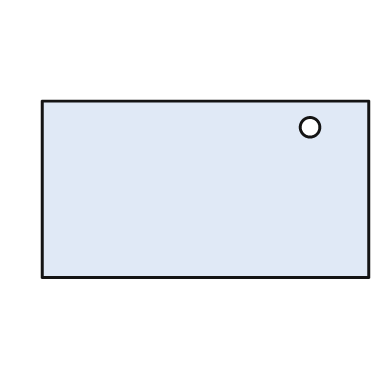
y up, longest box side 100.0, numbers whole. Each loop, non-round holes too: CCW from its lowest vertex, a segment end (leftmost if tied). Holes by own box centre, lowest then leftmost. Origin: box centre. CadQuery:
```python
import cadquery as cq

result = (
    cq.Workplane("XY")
    .moveTo(-50.0, -27.0)
    .lineTo(50.0, -27.0)
    .lineTo(50.0, 27.0)
    .lineTo(-50.0, 27.0)
    .close()
    .moveTo(32.0, 19.0)
    .circle(3.0)
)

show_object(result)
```